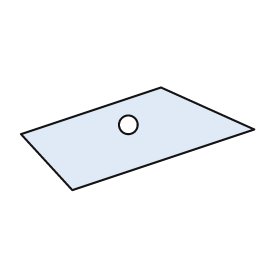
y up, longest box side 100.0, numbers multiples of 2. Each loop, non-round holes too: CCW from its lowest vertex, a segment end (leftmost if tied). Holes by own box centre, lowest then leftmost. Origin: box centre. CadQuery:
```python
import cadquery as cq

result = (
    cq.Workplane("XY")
    .moveTo(-28.0, -22.0)
    .lineTo(50.0, 4.0)
    .lineTo(10.0, 22.0)
    .lineTo(-50.0, 2.0)
    .close()
    .moveTo(-4.0, 6.0)
    .circle(4.0)
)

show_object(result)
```